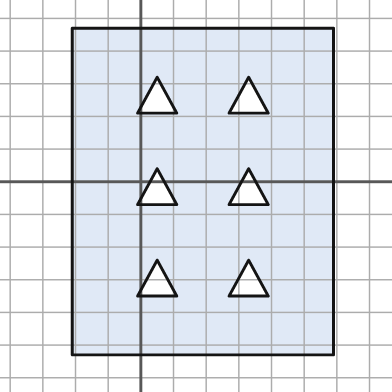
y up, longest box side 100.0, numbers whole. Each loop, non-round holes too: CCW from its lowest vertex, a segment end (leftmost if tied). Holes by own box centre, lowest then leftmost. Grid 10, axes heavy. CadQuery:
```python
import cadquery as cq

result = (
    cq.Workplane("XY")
    .moveTo(-21.0, -53.0)
    .lineTo(59.0, -53.0)
    .lineTo(59.0, 47.0)
    .lineTo(-21.0, 47.0)
    .close()
    .moveTo(-1.0, -35.0)
    .lineTo(11.0, -35.0)
    .lineTo(5.0, -24.0)
    .close()
    .moveTo(27.0, -35.0)
    .lineTo(39.0, -35.0)
    .lineTo(33.0, -24.0)
    .close()
    .moveTo(-1.0, -7.0)
    .lineTo(11.0, -7.0)
    .lineTo(5.0, 4.0)
    .close()
    .moveTo(27.0, -7.0)
    .lineTo(39.0, -7.0)
    .lineTo(33.0, 4.0)
    .close()
    .moveTo(-1.0, 21.0)
    .lineTo(11.0, 21.0)
    .lineTo(5.0, 32.0)
    .close()
    .moveTo(27.0, 21.0)
    .lineTo(39.0, 21.0)
    .lineTo(33.0, 32.0)
    .close()
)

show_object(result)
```